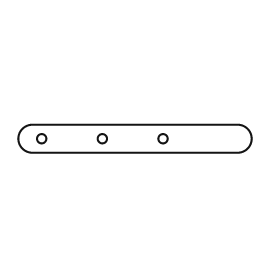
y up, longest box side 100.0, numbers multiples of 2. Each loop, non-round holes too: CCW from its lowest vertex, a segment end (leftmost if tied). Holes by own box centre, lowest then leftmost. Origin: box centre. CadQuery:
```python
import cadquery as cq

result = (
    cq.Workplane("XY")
    .moveTo(-44.0, -6.0)
    .lineTo(44.0, -6.0)
    .threePointArc((50.0, 0.0), (44.0, 6.0))
    .lineTo(-44.0, 6.0)
    .threePointArc((-50.0, 0.0), (-44.0, -6.0))
    .close()
    .moveTo(-40.0, 0.0)
    .circle(2.0)
    .moveTo(-14.0, 0.0)
    .circle(2.0)
    .moveTo(12.0, 0.0)
    .circle(2.0)
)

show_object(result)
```